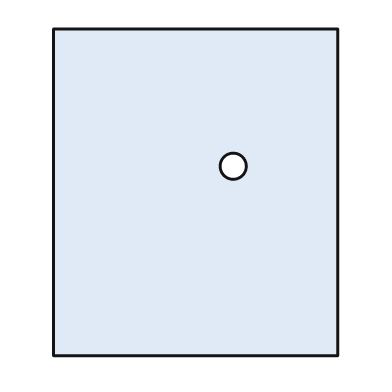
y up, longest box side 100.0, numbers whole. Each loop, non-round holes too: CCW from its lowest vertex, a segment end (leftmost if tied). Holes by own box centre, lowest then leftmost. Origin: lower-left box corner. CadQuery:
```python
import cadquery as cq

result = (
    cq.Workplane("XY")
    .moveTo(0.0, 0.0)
    .lineTo(87.0, 0.0)
    .lineTo(87.0, 100.0)
    .lineTo(0.0, 100.0)
    .close()
    .moveTo(55.0, 58.0)
    .circle(4.0)
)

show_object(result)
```